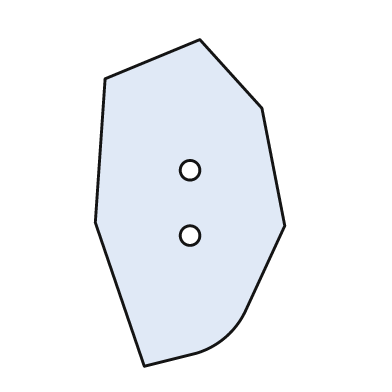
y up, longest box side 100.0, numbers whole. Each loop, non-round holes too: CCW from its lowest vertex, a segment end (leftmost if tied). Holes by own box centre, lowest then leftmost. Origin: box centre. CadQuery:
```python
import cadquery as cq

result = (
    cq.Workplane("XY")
    .moveTo(-14.0, -50.0)
    .lineTo(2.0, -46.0)
    .threePointArc((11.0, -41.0), (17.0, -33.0))
    .lineTo(29.0, -7.0)
    .lineTo(22.0, 29.0)
    .lineTo(3.0, 50.0)
    .lineTo(-26.0, 38.0)
    .lineTo(-29.0, -6.0)
    .close()
    .moveTo(0.0, -10.0)
    .circle(3.0)
    .moveTo(0.0, 10.0)
    .circle(3.0)
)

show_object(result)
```